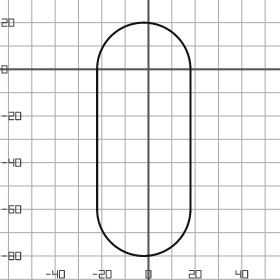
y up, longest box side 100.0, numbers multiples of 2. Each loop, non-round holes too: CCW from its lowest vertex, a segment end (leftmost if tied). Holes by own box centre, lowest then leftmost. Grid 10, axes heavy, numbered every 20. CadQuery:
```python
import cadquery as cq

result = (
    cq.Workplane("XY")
    .moveTo(-22.0, -60.0)
    .threePointArc((-2.0, -80.0), (18.0, -60.0))
    .lineTo(18.0, 0.0)
    .threePointArc((-2.0, 20.0), (-22.0, 0.0))
    .close()
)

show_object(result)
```